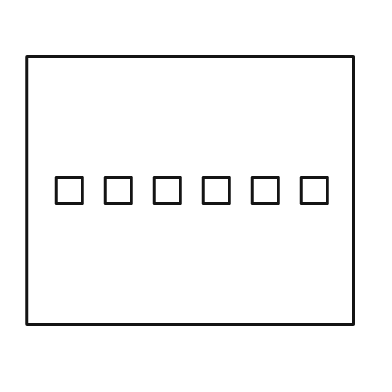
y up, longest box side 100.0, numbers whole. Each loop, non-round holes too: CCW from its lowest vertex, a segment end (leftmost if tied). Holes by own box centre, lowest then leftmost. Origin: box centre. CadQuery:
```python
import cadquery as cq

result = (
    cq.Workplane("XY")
    .moveTo(-50.0, -41.0)
    .lineTo(50.0, -41.0)
    .lineTo(50.0, 41.0)
    .lineTo(-50.0, 41.0)
    .close()
    .moveTo(-41.0, -4.0)
    .lineTo(-33.0, -4.0)
    .lineTo(-33.0, 4.0)
    .lineTo(-41.0, 4.0)
    .close()
    .moveTo(-26.0, -4.0)
    .lineTo(-18.0, -4.0)
    .lineTo(-18.0, 4.0)
    .lineTo(-26.0, 4.0)
    .close()
    .moveTo(-11.0, -4.0)
    .lineTo(-3.0, -4.0)
    .lineTo(-3.0, 4.0)
    .lineTo(-11.0, 4.0)
    .close()
    .moveTo(4.0, -4.0)
    .lineTo(12.0, -4.0)
    .lineTo(12.0, 4.0)
    .lineTo(4.0, 4.0)
    .close()
    .moveTo(19.0, -4.0)
    .lineTo(27.0, -4.0)
    .lineTo(27.0, 4.0)
    .lineTo(19.0, 4.0)
    .close()
    .moveTo(34.0, -4.0)
    .lineTo(42.0, -4.0)
    .lineTo(42.0, 4.0)
    .lineTo(34.0, 4.0)
    .close()
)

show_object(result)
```